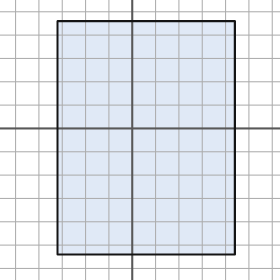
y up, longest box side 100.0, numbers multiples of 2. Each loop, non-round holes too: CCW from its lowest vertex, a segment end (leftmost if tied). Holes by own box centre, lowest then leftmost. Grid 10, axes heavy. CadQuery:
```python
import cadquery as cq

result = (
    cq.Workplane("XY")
    .moveTo(-32.0, -54.0)
    .lineTo(44.0, -54.0)
    .lineTo(44.0, 46.0)
    .lineTo(-32.0, 46.0)
    .close()
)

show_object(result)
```